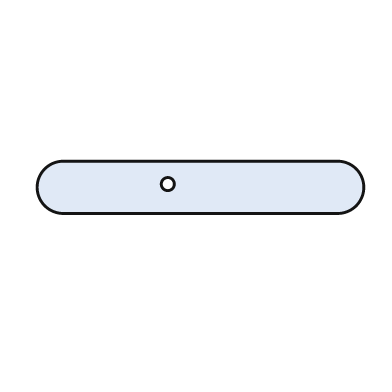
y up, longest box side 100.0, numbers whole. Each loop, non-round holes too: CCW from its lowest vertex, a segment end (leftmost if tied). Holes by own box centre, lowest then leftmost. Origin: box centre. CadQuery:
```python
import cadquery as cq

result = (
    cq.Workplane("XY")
    .moveTo(-42.0, -8.0)
    .lineTo(42.0, -8.0)
    .threePointArc((50.0, 0.0), (42.0, 8.0))
    .lineTo(-42.0, 8.0)
    .threePointArc((-50.0, 0.0), (-42.0, -8.0))
    .close()
    .moveTo(-10.0, 1.0)
    .circle(2.0)
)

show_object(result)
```